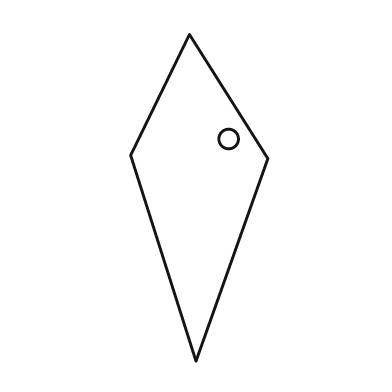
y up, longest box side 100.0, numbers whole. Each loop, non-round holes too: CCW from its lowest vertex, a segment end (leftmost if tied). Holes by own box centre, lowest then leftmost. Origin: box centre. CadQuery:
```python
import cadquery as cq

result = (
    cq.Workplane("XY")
    .moveTo(-1.0, -50.0)
    .lineTo(21.0, 12.0)
    .lineTo(-3.0, 50.0)
    .lineTo(-21.0, 13.0)
    .close()
    .moveTo(9.0, 18.0)
    .circle(3.0)
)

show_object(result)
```